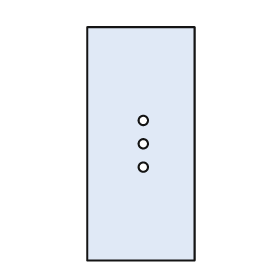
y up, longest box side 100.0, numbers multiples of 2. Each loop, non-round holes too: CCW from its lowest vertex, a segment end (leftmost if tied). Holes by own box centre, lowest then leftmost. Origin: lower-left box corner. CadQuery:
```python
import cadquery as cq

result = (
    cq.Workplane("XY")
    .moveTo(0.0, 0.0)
    .lineTo(46.0, 0.0)
    .lineTo(46.0, 100.0)
    .lineTo(0.0, 100.0)
    .close()
    .moveTo(24.0, 40.0)
    .circle(2.0)
    .moveTo(24.0, 50.0)
    .circle(2.0)
    .moveTo(24.0, 60.0)
    .circle(2.0)
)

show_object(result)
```